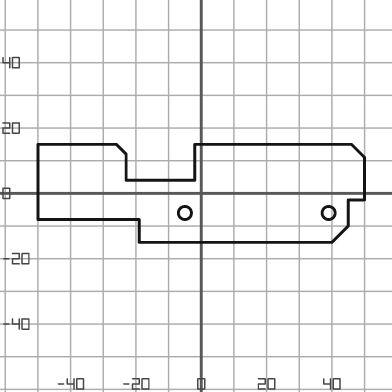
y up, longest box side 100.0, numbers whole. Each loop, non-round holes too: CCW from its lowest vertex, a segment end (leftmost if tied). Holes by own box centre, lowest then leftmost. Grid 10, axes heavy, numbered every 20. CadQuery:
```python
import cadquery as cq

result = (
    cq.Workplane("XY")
    .moveTo(-19.0, -15.0)
    .lineTo(40.0, -15.0)
    .lineTo(45.0, -10.0)
    .lineTo(45.0, -2.0)
    .lineTo(50.0, -2.0)
    .lineTo(50.0, 11.0)
    .lineTo(46.0, 15.0)
    .lineTo(-2.0, 15.0)
    .lineTo(-2.0, 4.0)
    .lineTo(-23.0, 4.0)
    .lineTo(-23.0, 12.0)
    .lineTo(-26.0, 15.0)
    .lineTo(-50.0, 15.0)
    .lineTo(-50.0, -8.0)
    .lineTo(-19.0, -8.0)
    .close()
    .moveTo(-5.0, -6.0)
    .circle(2.0)
    .moveTo(39.0, -6.0)
    .circle(2.0)
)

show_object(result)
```